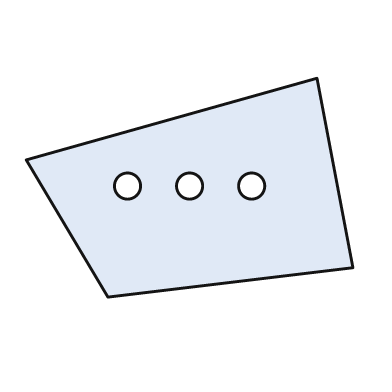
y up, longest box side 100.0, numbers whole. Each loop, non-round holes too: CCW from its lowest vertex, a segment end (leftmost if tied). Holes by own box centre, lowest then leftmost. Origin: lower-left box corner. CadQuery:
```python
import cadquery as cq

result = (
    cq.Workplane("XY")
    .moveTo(25.0, 0.0)
    .lineTo(100.0, 9.0)
    .lineTo(89.0, 67.0)
    .lineTo(0.0, 42.0)
    .close()
    .moveTo(31.0, 34.0)
    .circle(4.0)
    .moveTo(50.0, 34.0)
    .circle(4.0)
    .moveTo(69.0, 34.0)
    .circle(4.0)
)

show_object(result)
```